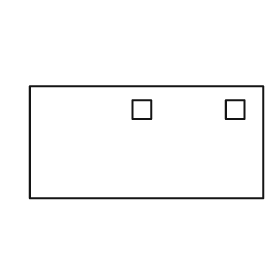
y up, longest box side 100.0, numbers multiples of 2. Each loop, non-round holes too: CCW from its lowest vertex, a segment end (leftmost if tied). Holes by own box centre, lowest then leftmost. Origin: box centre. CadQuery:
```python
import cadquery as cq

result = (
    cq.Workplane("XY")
    .moveTo(-50.0, -24.0)
    .lineTo(50.0, -24.0)
    .lineTo(50.0, 24.0)
    .lineTo(-50.0, 24.0)
    .close()
    .moveTo(-6.0, 10.0)
    .lineTo(2.0, 10.0)
    .lineTo(2.0, 18.0)
    .lineTo(-6.0, 18.0)
    .close()
    .moveTo(34.0, 10.0)
    .lineTo(42.0, 10.0)
    .lineTo(42.0, 18.0)
    .lineTo(34.0, 18.0)
    .close()
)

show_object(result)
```